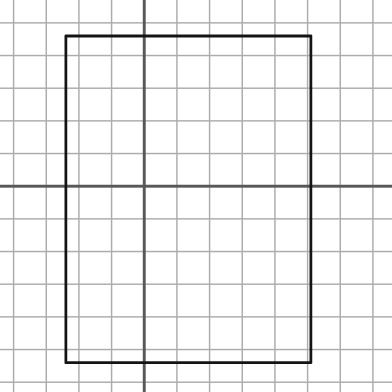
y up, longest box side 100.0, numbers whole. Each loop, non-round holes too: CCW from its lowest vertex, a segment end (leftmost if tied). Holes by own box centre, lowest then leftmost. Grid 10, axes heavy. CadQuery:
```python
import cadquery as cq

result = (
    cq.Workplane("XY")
    .moveTo(-24.0, -54.0)
    .lineTo(51.0, -54.0)
    .lineTo(51.0, 46.0)
    .lineTo(-24.0, 46.0)
    .close()
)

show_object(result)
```